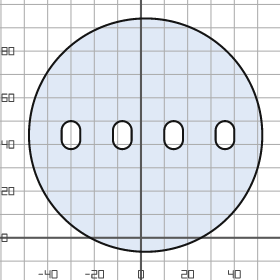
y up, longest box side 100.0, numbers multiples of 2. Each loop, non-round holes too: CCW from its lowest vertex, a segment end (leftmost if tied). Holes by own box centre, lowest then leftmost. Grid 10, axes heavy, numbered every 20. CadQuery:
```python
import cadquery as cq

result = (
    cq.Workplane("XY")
    .moveTo(2.0, 44.0)
    .circle(50.0)
    .moveTo(-34.0, 42.0)
    .threePointArc((-30.0, 38.0), (-26.0, 42.0))
    .lineTo(-26.0, 46.0)
    .threePointArc((-30.0, 50.0), (-34.0, 46.0))
    .close()
    .moveTo(-12.0, 42.0)
    .threePointArc((-8.0, 38.0), (-4.0, 42.0))
    .lineTo(-4.0, 46.0)
    .threePointArc((-8.0, 50.0), (-12.0, 46.0))
    .close()
    .moveTo(10.0, 42.0)
    .threePointArc((14.0, 38.0), (18.0, 42.0))
    .lineTo(18.0, 46.0)
    .threePointArc((14.0, 50.0), (10.0, 46.0))
    .close()
    .moveTo(32.0, 42.0)
    .threePointArc((36.0, 38.0), (40.0, 42.0))
    .lineTo(40.0, 46.0)
    .threePointArc((36.0, 50.0), (32.0, 46.0))
    .close()
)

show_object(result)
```